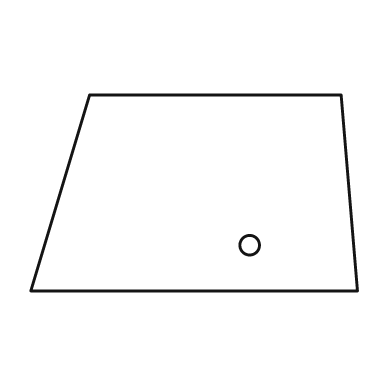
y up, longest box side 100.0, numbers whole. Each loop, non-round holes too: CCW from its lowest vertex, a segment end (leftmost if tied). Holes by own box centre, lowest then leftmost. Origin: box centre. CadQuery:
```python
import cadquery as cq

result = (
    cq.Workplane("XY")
    .moveTo(-50.0, -30.0)
    .lineTo(50.0, -30.0)
    .lineTo(45.0, 30.0)
    .lineTo(-32.0, 30.0)
    .close()
    .moveTo(17.0, -16.0)
    .circle(3.0)
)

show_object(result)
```